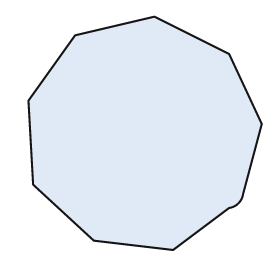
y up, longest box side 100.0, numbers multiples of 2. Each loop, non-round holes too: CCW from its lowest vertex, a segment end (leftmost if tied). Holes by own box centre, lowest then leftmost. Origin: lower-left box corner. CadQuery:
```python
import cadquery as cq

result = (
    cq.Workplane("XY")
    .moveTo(62.0, 0.0)
    .lineTo(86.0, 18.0)
    .threePointArc((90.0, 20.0), (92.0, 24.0))
    .lineTo(100.0, 54.0)
    .lineTo(86.0, 84.0)
    .lineTo(54.0, 100.0)
    .lineTo(20.0, 92.0)
    .lineTo(0.0, 64.0)
    .lineTo(2.0, 28.0)
    .lineTo(28.0, 4.0)
    .close()
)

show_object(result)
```